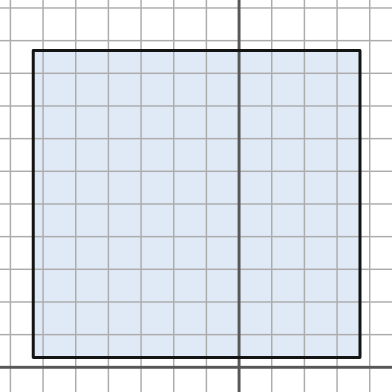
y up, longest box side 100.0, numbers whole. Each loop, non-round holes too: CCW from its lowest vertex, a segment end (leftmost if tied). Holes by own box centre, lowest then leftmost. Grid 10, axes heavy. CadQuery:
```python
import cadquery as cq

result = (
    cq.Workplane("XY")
    .moveTo(-63.0, 3.0)
    .lineTo(37.0, 3.0)
    .lineTo(37.0, 97.0)
    .lineTo(-63.0, 97.0)
    .close()
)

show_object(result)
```